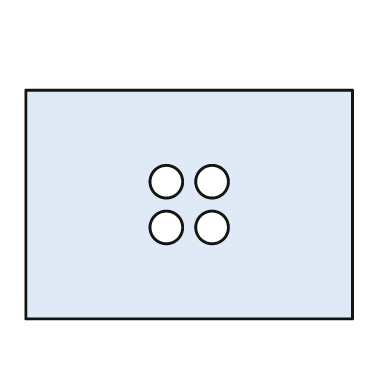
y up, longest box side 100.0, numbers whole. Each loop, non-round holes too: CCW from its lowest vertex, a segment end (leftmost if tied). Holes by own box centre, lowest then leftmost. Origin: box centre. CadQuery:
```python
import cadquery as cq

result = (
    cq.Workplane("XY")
    .moveTo(-50.0, -35.0)
    .lineTo(50.0, -35.0)
    .lineTo(50.0, 35.0)
    .lineTo(-50.0, 35.0)
    .close()
    .moveTo(-7.0, -7.0)
    .circle(5.0)
    .moveTo(7.0, -7.0)
    .circle(5.0)
    .moveTo(-7.0, 7.0)
    .circle(5.0)
    .moveTo(7.0, 7.0)
    .circle(5.0)
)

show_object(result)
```